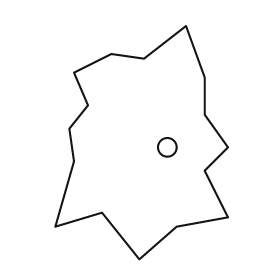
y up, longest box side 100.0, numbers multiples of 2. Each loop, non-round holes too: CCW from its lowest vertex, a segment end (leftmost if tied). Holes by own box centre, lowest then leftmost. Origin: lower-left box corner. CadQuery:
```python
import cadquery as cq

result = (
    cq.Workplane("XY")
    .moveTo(36.0, 0.0)
    .lineTo(52.0, 14.0)
    .lineTo(74.0, 18.0)
    .lineTo(64.0, 38.0)
    .lineTo(74.0, 48.0)
    .lineTo(64.0, 62.0)
    .lineTo(64.0, 78.0)
    .lineTo(56.0, 100.0)
    .lineTo(38.0, 86.0)
    .lineTo(24.0, 88.0)
    .lineTo(8.0, 80.0)
    .lineTo(14.0, 66.0)
    .lineTo(6.0, 56.0)
    .lineTo(8.0, 42.0)
    .lineTo(0.0, 14.0)
    .lineTo(20.0, 20.0)
    .close()
    .moveTo(48.0, 48.0)
    .circle(4.0)
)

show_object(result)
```